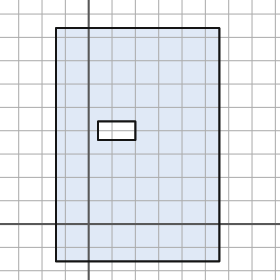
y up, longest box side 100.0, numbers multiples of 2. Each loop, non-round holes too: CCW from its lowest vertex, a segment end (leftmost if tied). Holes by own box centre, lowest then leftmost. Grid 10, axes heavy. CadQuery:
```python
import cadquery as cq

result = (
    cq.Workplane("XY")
    .moveTo(-14.0, -16.0)
    .lineTo(56.0, -16.0)
    .lineTo(56.0, 84.0)
    .lineTo(-14.0, 84.0)
    .close()
    .moveTo(4.0, 36.0)
    .lineTo(20.0, 36.0)
    .lineTo(20.0, 44.0)
    .lineTo(4.0, 44.0)
    .close()
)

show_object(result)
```